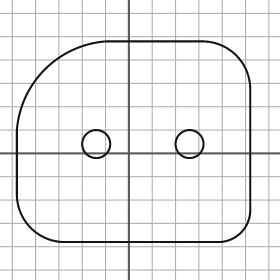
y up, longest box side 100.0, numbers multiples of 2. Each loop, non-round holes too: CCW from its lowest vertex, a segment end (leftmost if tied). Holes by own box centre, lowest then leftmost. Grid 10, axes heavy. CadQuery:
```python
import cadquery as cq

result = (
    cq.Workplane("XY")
    .moveTo(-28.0, -38.0)
    .lineTo(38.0, -38.0)
    .threePointArc((48.0, -34.0), (52.0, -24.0))
    .lineTo(52.0, 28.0)
    .threePointArc((46.0, 42.0), (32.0, 48.0))
    .lineTo(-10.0, 48.0)
    .threePointArc((-36.0, 36.0), (-48.0, 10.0))
    .lineTo(-48.0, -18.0)
    .threePointArc((-42.0, -32.0), (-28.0, -38.0))
    .close()
    .moveTo(-14.0, 4.0)
    .circle(6.0)
    .moveTo(26.0, 4.0)
    .circle(6.0)
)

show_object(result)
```